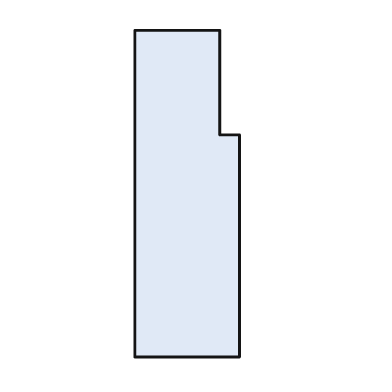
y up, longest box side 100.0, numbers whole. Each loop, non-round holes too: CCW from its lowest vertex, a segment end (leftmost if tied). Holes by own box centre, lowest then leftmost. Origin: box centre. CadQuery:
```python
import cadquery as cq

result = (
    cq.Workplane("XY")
    .moveTo(-16.0, -50.0)
    .lineTo(16.0, -50.0)
    .lineTo(16.0, 18.0)
    .lineTo(10.0, 18.0)
    .lineTo(10.0, 50.0)
    .lineTo(-16.0, 50.0)
    .close()
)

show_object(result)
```